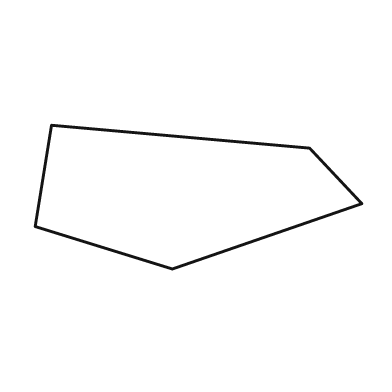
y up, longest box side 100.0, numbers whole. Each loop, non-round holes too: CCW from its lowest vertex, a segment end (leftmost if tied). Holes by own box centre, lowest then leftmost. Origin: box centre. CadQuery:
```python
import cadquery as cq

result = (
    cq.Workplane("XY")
    .moveTo(-8.0, -22.0)
    .lineTo(50.0, -2.0)
    .lineTo(34.0, 15.0)
    .lineTo(-45.0, 22.0)
    .lineTo(-50.0, -9.0)
    .close()
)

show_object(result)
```